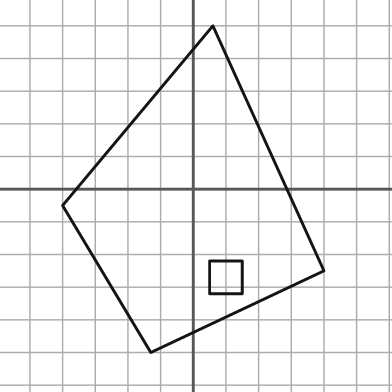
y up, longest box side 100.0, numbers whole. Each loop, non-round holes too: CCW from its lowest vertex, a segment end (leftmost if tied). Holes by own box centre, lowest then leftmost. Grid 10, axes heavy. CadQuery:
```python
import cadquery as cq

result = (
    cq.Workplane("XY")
    .moveTo(-13.0, -50.0)
    .lineTo(40.0, -25.0)
    .lineTo(6.0, 50.0)
    .lineTo(-40.0, -5.0)
    .close()
    .moveTo(5.0, -32.0)
    .lineTo(15.0, -32.0)
    .lineTo(15.0, -22.0)
    .lineTo(5.0, -22.0)
    .close()
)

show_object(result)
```